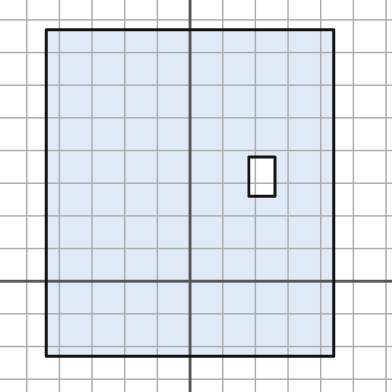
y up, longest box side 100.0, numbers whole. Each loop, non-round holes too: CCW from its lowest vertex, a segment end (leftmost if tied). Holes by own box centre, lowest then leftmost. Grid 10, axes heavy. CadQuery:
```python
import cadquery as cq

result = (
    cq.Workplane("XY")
    .moveTo(-44.0, -23.0)
    .lineTo(44.0, -23.0)
    .lineTo(44.0, 77.0)
    .lineTo(-44.0, 77.0)
    .close()
    .moveTo(18.0, 26.0)
    .lineTo(26.0, 26.0)
    .lineTo(26.0, 38.0)
    .lineTo(18.0, 38.0)
    .close()
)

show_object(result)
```